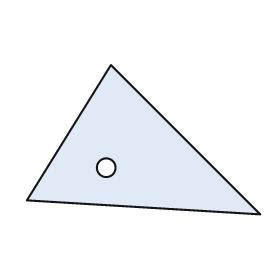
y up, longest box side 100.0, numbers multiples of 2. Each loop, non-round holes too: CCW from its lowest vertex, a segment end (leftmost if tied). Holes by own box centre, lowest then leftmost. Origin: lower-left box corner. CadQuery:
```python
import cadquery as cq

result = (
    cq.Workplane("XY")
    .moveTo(100.0, 0.0)
    .lineTo(36.0, 64.0)
    .lineTo(0.0, 6.0)
    .close()
    .moveTo(34.0, 20.0)
    .circle(4.0)
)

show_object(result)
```